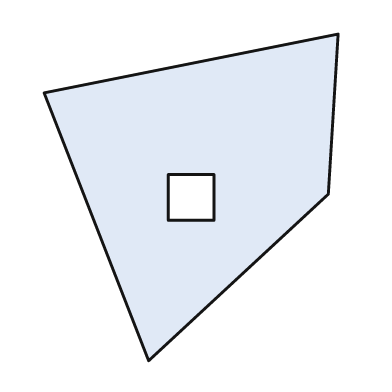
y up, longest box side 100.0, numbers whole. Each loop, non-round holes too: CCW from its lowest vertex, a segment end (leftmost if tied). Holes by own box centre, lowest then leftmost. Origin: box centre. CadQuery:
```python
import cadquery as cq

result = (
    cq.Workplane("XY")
    .moveTo(-13.0, -50.0)
    .lineTo(42.0, 1.0)
    .lineTo(45.0, 50.0)
    .lineTo(-45.0, 32.0)
    .close()
    .moveTo(-7.0, -7.0)
    .lineTo(7.0, -7.0)
    .lineTo(7.0, 7.0)
    .lineTo(-7.0, 7.0)
    .close()
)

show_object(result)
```